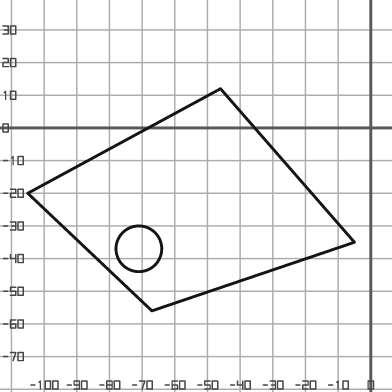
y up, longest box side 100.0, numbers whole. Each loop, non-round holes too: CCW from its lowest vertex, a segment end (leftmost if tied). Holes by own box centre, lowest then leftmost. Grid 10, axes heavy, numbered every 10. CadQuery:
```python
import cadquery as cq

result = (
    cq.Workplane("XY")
    .moveTo(-67.0, -56.0)
    .lineTo(-5.0, -35.0)
    .lineTo(-46.0, 12.0)
    .lineTo(-105.0, -20.0)
    .close()
    .moveTo(-71.0, -37.0)
    .circle(7.0)
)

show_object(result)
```